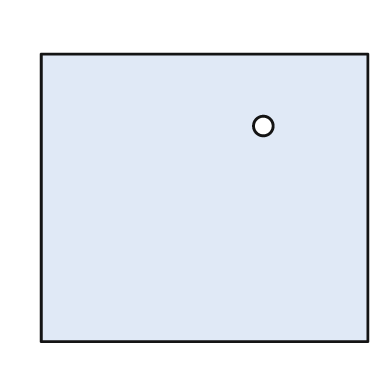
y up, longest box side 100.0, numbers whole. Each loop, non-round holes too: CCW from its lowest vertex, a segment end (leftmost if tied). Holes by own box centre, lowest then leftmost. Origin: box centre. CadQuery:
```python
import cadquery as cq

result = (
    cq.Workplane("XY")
    .moveTo(-50.0, -44.0)
    .lineTo(50.0, -44.0)
    .lineTo(50.0, 44.0)
    .lineTo(-50.0, 44.0)
    .close()
    .moveTo(18.0, 22.0)
    .circle(3.0)
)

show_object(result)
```